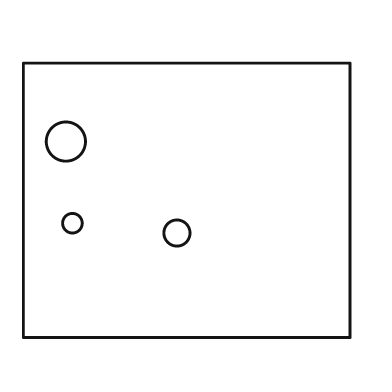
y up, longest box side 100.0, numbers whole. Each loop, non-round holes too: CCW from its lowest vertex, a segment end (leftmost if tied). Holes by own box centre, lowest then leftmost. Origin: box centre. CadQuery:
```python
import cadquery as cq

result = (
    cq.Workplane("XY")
    .moveTo(-50.0, -42.0)
    .lineTo(50.0, -42.0)
    .lineTo(50.0, 42.0)
    .lineTo(-50.0, 42.0)
    .close()
    .moveTo(-3.0, -10.0)
    .circle(4.0)
    .moveTo(-35.0, -7.0)
    .circle(3.0)
    .moveTo(-37.0, 18.0)
    .circle(6.0)
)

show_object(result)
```